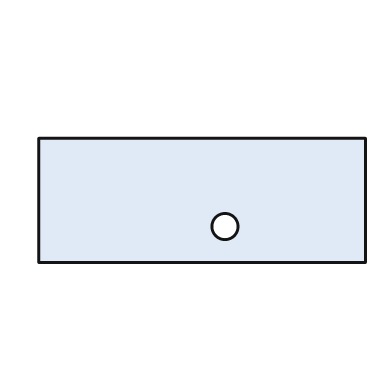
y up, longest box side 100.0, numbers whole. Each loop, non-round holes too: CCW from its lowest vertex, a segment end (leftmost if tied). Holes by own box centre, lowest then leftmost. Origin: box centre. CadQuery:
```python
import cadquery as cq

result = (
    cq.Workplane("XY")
    .moveTo(-50.0, -19.0)
    .lineTo(50.0, -19.0)
    .lineTo(50.0, 19.0)
    .lineTo(-50.0, 19.0)
    .close()
    .moveTo(7.0, -8.0)
    .circle(4.0)
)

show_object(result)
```